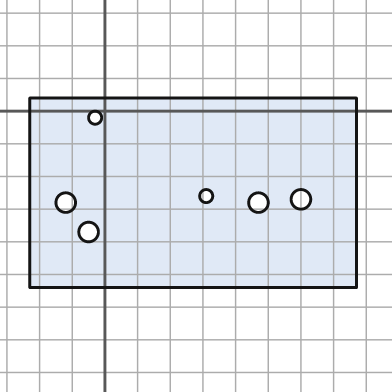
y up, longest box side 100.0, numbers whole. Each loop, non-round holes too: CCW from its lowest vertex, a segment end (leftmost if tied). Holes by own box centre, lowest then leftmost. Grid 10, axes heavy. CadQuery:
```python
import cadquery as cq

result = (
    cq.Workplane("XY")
    .moveTo(-23.0, -54.0)
    .lineTo(77.0, -54.0)
    .lineTo(77.0, 4.0)
    .lineTo(-23.0, 4.0)
    .close()
    .moveTo(-5.0, -37.0)
    .circle(3.0)
    .moveTo(-12.0, -28.0)
    .circle(3.0)
    .moveTo(47.0, -28.0)
    .circle(3.0)
    .moveTo(60.0, -27.0)
    .circle(3.0)
    .moveTo(31.0, -26.0)
    .circle(2.0)
    .moveTo(-3.0, -2.0)
    .circle(2.0)
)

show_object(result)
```